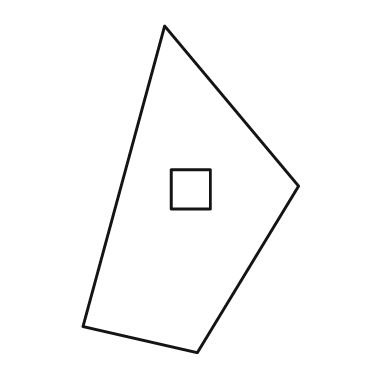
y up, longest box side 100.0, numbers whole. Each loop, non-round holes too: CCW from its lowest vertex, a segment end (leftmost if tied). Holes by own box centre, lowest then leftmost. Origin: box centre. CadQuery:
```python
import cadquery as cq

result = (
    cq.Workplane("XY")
    .moveTo(2.0, -50.0)
    .lineTo(33.0, 1.0)
    .lineTo(-8.0, 50.0)
    .lineTo(-33.0, -42.0)
    .close()
    .moveTo(-6.0, -6.0)
    .lineTo(6.0, -6.0)
    .lineTo(6.0, 6.0)
    .lineTo(-6.0, 6.0)
    .close()
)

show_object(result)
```